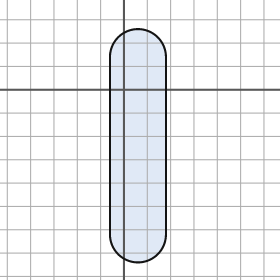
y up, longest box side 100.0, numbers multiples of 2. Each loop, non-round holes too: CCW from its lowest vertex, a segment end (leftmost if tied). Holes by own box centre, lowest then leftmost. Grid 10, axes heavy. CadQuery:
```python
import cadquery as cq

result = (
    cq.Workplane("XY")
    .moveTo(-6.0, -62.0)
    .threePointArc((6.0, -74.0), (18.0, -62.0))
    .lineTo(18.0, 14.0)
    .threePointArc((6.0, 26.0), (-6.0, 14.0))
    .close()
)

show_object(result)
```